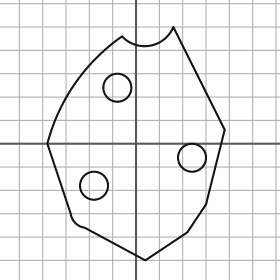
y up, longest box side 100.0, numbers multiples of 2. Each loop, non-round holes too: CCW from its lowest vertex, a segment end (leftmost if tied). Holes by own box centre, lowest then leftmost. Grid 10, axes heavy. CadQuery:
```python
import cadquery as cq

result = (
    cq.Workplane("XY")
    .moveTo(4.0, -50.0)
    .lineTo(22.0, -38.0)
    .lineTo(30.0, -26.0)
    .lineTo(38.0, 6.0)
    .lineTo(16.0, 50.0)
    .threePointArc((6.0, 42.0), (-6.0, 46.0))
    .threePointArc((-26.0, 26.0), (-38.0, 0.0))
    .lineTo(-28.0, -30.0)
    .threePointArc((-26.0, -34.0), (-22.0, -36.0))
    .close()
    .moveTo(-18.0, -18.0)
    .circle(6.0)
    .moveTo(24.0, -6.0)
    .circle(6.0)
    .moveTo(-8.0, 24.0)
    .circle(6.0)
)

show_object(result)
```